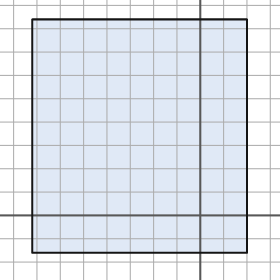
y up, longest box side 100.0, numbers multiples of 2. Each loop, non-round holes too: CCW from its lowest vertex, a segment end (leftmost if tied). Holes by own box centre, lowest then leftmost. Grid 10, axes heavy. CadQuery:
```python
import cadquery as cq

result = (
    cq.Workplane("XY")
    .moveTo(-72.0, -16.0)
    .lineTo(20.0, -16.0)
    .lineTo(20.0, 84.0)
    .lineTo(-72.0, 84.0)
    .close()
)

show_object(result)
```